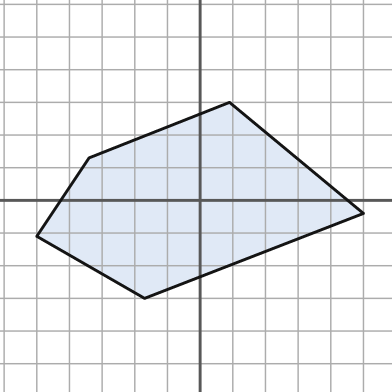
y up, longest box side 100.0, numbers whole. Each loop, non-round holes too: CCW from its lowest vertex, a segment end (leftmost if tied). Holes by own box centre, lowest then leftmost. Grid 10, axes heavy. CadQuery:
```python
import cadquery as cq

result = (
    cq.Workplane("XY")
    .moveTo(-17.0, -30.0)
    .lineTo(50.0, -4.0)
    .lineTo(9.0, 30.0)
    .lineTo(-34.0, 13.0)
    .lineTo(-50.0, -11.0)
    .close()
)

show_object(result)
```